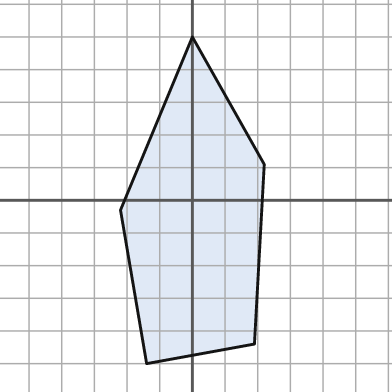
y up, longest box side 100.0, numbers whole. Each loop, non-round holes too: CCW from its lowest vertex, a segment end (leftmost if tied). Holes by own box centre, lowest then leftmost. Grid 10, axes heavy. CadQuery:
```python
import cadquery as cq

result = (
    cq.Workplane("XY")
    .moveTo(-14.0, -50.0)
    .lineTo(19.0, -44.0)
    .lineTo(22.0, 11.0)
    .lineTo(0.0, 50.0)
    .lineTo(-22.0, -3.0)
    .close()
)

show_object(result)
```